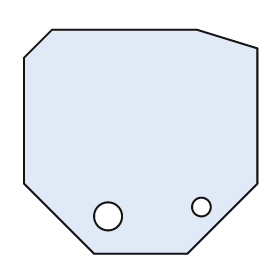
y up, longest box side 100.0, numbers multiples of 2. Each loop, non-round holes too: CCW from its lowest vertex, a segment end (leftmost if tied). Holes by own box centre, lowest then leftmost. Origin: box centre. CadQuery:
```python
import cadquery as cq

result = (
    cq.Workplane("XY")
    .moveTo(-20.0, -48.0)
    .lineTo(20.0, -48.0)
    .lineTo(50.0, -18.0)
    .lineTo(50.0, 40.0)
    .lineTo(24.0, 48.0)
    .lineTo(-38.0, 48.0)
    .lineTo(-50.0, 36.0)
    .lineTo(-50.0, -18.0)
    .close()
    .moveTo(-14.0, -32.0)
    .circle(6.0)
    .moveTo(26.0, -28.0)
    .circle(4.0)
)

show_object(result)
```